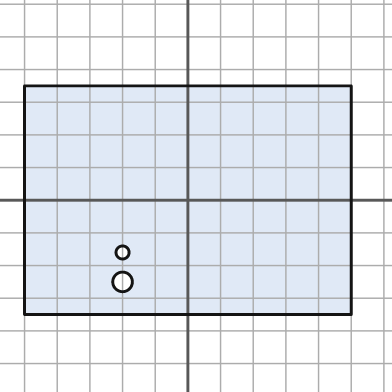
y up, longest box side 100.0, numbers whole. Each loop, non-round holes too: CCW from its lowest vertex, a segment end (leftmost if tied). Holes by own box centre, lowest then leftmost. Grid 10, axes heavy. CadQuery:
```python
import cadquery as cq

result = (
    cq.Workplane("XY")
    .moveTo(-50.0, -35.0)
    .lineTo(50.0, -35.0)
    .lineTo(50.0, 35.0)
    .lineTo(-50.0, 35.0)
    .close()
    .moveTo(-20.0, -25.0)
    .circle(3.0)
    .moveTo(-20.0, -16.0)
    .circle(2.0)
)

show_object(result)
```